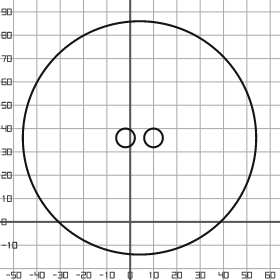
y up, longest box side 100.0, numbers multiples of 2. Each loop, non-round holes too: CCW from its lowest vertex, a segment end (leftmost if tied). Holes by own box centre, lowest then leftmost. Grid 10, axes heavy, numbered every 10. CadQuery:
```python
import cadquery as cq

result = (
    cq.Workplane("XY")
    .moveTo(4.0, 36.0)
    .circle(50.0)
    .moveTo(-2.0, 36.0)
    .circle(4.0)
    .moveTo(10.0, 36.0)
    .circle(4.0)
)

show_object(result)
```